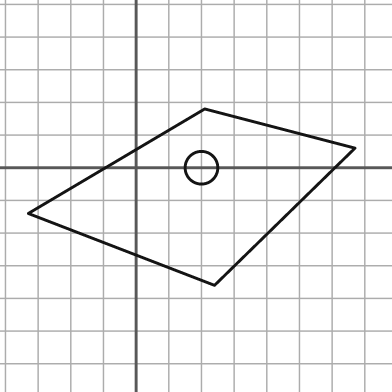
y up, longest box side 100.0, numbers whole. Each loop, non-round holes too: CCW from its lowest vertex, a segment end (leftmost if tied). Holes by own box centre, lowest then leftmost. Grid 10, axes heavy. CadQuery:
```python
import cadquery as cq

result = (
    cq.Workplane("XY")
    .moveTo(24.0, -36.0)
    .lineTo(67.0, 6.0)
    .lineTo(21.0, 18.0)
    .lineTo(-33.0, -14.0)
    .close()
    .moveTo(20.0, 0.0)
    .circle(5.0)
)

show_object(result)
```